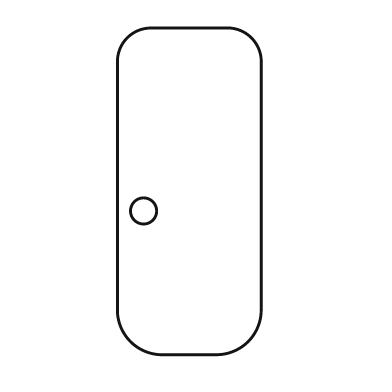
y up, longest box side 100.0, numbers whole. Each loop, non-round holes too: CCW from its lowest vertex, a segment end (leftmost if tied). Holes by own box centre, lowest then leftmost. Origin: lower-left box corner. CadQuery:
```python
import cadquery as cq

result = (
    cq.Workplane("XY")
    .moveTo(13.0, 0.0)
    .lineTo(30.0, 0.0)
    .threePointArc((40.0, 4.0), (44.0, 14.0))
    .lineTo(44.0, 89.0)
    .threePointArc((41.0, 97.0), (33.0, 100.0))
    .lineTo(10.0, 100.0)
    .threePointArc((3.0, 97.0), (0.0, 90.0))
    .lineTo(0.0, 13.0)
    .threePointArc((4.0, 4.0), (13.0, 0.0))
    .close()
    .moveTo(8.0, 44.0)
    .circle(4.0)
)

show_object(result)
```